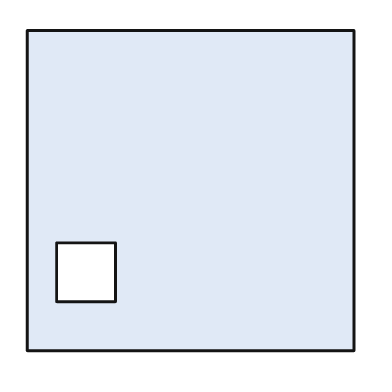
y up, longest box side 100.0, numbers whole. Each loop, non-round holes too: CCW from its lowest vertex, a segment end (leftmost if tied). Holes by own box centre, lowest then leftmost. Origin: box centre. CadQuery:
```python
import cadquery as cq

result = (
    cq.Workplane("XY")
    .moveTo(-50.0, -49.0)
    .lineTo(50.0, -49.0)
    .lineTo(50.0, 49.0)
    .lineTo(-50.0, 49.0)
    .close()
    .moveTo(-41.0, -34.0)
    .lineTo(-23.0, -34.0)
    .lineTo(-23.0, -16.0)
    .lineTo(-41.0, -16.0)
    .close()
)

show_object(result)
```